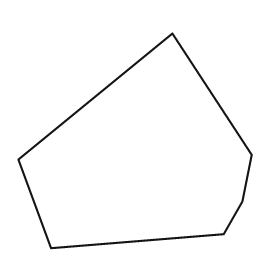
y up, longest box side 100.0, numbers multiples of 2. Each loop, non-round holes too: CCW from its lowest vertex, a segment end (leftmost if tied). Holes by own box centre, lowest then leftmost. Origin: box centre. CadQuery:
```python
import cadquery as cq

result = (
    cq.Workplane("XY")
    .moveTo(-36.0, -46.0)
    .lineTo(38.0, -40.0)
    .lineTo(46.0, -26.0)
    .lineTo(50.0, -6.0)
    .lineTo(16.0, 46.0)
    .lineTo(-50.0, -8.0)
    .close()
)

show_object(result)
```